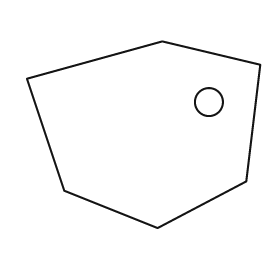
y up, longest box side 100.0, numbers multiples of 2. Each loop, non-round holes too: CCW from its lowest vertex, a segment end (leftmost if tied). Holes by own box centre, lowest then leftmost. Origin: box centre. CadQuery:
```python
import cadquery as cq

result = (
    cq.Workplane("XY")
    .moveTo(6.0, -40.0)
    .lineTo(44.0, -20.0)
    .lineTo(50.0, 30.0)
    .lineTo(8.0, 40.0)
    .lineTo(-50.0, 24.0)
    .lineTo(-34.0, -24.0)
    .close()
    .moveTo(28.0, 14.0)
    .circle(6.0)
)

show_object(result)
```